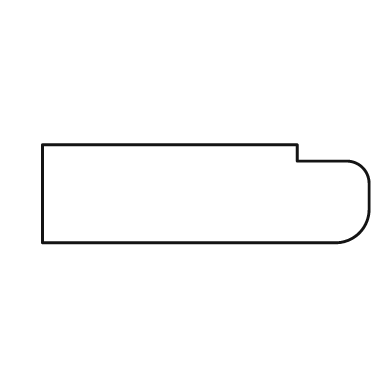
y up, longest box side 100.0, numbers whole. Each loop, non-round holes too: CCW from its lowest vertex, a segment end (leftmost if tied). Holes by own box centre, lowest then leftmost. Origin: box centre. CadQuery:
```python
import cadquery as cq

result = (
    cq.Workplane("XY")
    .moveTo(-50.0, -15.0)
    .lineTo(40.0, -15.0)
    .threePointArc((47.0, -12.0), (50.0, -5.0))
    .lineTo(50.0, 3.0)
    .threePointArc((48.0, 8.0), (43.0, 10.0))
    .lineTo(28.0, 10.0)
    .lineTo(28.0, 15.0)
    .lineTo(-50.0, 15.0)
    .close()
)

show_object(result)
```